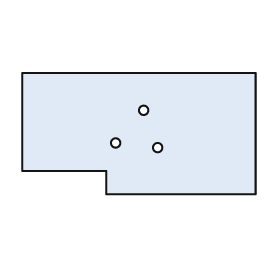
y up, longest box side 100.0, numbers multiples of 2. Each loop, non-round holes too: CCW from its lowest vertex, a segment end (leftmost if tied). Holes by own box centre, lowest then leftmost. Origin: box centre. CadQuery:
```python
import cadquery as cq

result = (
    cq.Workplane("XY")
    .moveTo(-14.0, -26.0)
    .lineTo(50.0, -26.0)
    .lineTo(50.0, 26.0)
    .lineTo(-50.0, 26.0)
    .lineTo(-50.0, -16.0)
    .lineTo(-14.0, -16.0)
    .close()
    .moveTo(8.0, -6.0)
    .circle(2.0)
    .moveTo(-10.0, -4.0)
    .circle(2.0)
    .moveTo(2.0, 10.0)
    .circle(2.0)
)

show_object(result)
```